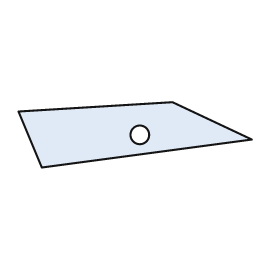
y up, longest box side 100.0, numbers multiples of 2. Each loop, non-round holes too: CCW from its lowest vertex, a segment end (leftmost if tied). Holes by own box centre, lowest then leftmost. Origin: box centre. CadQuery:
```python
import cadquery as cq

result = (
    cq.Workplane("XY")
    .moveTo(-40.0, -14.0)
    .lineTo(50.0, -2.0)
    .lineTo(16.0, 14.0)
    .lineTo(-50.0, 10.0)
    .close()
    .moveTo(2.0, 0.0)
    .circle(4.0)
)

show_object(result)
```